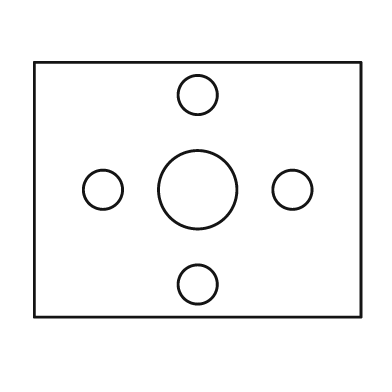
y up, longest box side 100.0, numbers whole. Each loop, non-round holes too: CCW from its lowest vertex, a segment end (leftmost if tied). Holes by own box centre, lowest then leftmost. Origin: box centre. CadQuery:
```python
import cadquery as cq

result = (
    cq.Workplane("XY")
    .moveTo(-50.0, -39.0)
    .lineTo(50.0, -39.0)
    .lineTo(50.0, 39.0)
    .lineTo(-50.0, 39.0)
    .close()
    .moveTo(0.0, -29.0)
    .circle(6.0)
    .moveTo(-29.0, 0.0)
    .circle(6.0)
    .moveTo(0.0, 0.0)
    .circle(12.0)
    .moveTo(29.0, 0.0)
    .circle(6.0)
    .moveTo(0.0, 29.0)
    .circle(6.0)
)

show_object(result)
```